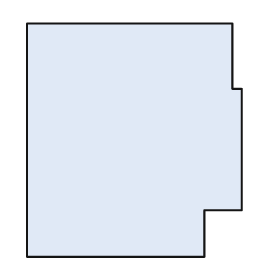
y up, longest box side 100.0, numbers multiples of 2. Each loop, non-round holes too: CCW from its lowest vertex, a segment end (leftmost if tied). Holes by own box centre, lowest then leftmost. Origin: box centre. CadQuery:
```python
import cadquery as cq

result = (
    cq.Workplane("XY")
    .moveTo(-46.0, -50.0)
    .lineTo(30.0, -50.0)
    .lineTo(30.0, -30.0)
    .lineTo(46.0, -30.0)
    .lineTo(46.0, 22.0)
    .lineTo(42.0, 22.0)
    .lineTo(42.0, 50.0)
    .lineTo(-46.0, 50.0)
    .close()
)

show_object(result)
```